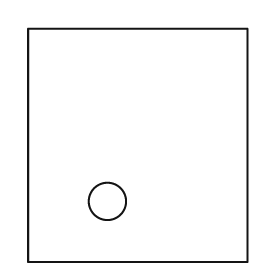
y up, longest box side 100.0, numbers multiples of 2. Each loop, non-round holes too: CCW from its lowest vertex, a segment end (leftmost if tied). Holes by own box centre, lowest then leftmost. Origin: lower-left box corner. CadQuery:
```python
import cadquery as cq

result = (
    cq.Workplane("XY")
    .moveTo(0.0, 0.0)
    .lineTo(94.0, 0.0)
    .lineTo(94.0, 100.0)
    .lineTo(0.0, 100.0)
    .close()
    .moveTo(34.0, 26.0)
    .circle(8.0)
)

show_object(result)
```